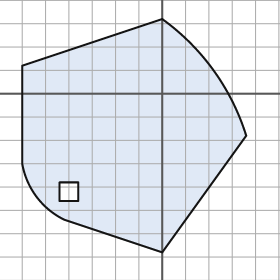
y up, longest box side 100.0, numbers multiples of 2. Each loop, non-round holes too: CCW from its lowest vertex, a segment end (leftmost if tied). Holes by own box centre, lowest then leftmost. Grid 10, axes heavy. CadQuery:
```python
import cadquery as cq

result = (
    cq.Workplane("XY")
    .moveTo(0.0, -68.0)
    .lineTo(36.0, -18.0)
    .threePointArc((22.0, 10.0), (0.0, 32.0))
    .lineTo(-60.0, 12.0)
    .lineTo(-60.0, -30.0)
    .threePointArc((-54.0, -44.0), (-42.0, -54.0))
    .close()
    .moveTo(-44.0, -46.0)
    .lineTo(-36.0, -46.0)
    .lineTo(-36.0, -38.0)
    .lineTo(-44.0, -38.0)
    .close()
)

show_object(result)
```